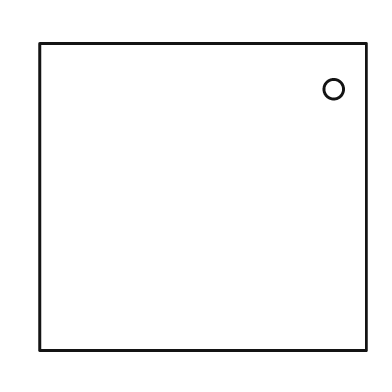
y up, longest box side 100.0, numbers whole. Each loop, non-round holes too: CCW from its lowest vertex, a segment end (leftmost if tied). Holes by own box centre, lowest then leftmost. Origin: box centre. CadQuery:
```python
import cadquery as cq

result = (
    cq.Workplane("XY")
    .moveTo(-50.0, -47.0)
    .lineTo(50.0, -47.0)
    .lineTo(50.0, 47.0)
    .lineTo(-50.0, 47.0)
    .close()
    .moveTo(40.0, 33.0)
    .circle(3.0)
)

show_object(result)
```